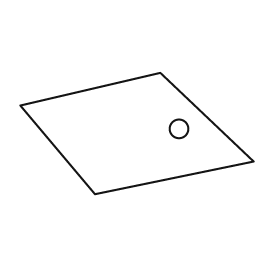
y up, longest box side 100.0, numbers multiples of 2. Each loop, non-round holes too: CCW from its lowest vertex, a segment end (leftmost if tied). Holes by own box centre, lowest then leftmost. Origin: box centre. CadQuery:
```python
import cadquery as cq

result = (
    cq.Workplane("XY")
    .moveTo(-18.0, -26.0)
    .lineTo(50.0, -12.0)
    .lineTo(10.0, 26.0)
    .lineTo(-50.0, 12.0)
    .close()
    .moveTo(18.0, 2.0)
    .circle(4.0)
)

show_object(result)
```